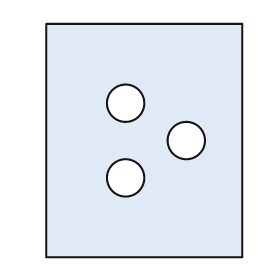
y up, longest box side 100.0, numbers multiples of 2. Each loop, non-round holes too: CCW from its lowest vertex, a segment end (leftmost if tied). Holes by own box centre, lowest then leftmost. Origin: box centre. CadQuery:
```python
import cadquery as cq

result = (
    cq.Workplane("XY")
    .moveTo(-42.0, -50.0)
    .lineTo(42.0, -50.0)
    .lineTo(42.0, 50.0)
    .lineTo(-42.0, 50.0)
    .close()
    .moveTo(-8.0, -16.0)
    .circle(8.0)
    .moveTo(18.0, 0.0)
    .circle(8.0)
    .moveTo(-8.0, 16.0)
    .circle(8.0)
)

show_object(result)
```